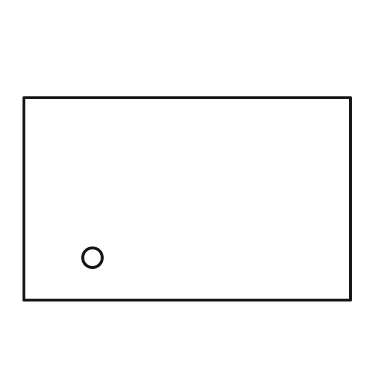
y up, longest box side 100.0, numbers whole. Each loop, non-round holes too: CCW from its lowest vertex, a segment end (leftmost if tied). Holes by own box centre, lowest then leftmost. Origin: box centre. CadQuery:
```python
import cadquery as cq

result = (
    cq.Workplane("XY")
    .moveTo(-50.0, -31.0)
    .lineTo(50.0, -31.0)
    .lineTo(50.0, 31.0)
    .lineTo(-50.0, 31.0)
    .close()
    .moveTo(-29.0, -18.0)
    .circle(3.0)
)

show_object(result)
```